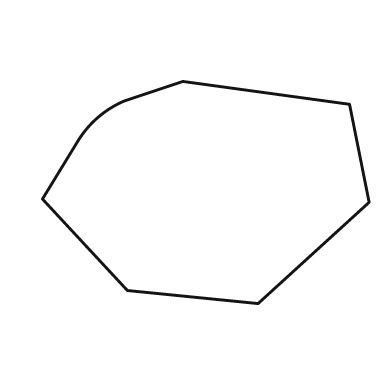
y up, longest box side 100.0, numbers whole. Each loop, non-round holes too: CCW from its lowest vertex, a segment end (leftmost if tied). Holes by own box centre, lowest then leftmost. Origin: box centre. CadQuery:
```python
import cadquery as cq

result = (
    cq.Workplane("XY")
    .moveTo(16.0, -34.0)
    .lineTo(50.0, -3.0)
    .lineTo(44.0, 27.0)
    .lineTo(-7.0, 34.0)
    .lineTo(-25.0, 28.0)
    .threePointArc((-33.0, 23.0), (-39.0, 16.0))
    .lineTo(-50.0, -2.0)
    .lineTo(-24.0, -30.0)
    .close()
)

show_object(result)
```